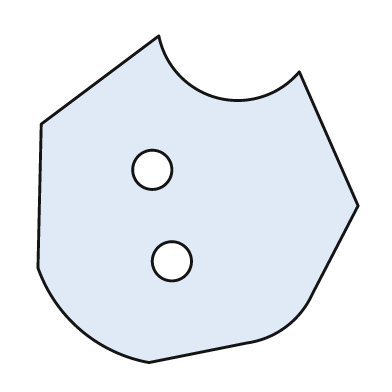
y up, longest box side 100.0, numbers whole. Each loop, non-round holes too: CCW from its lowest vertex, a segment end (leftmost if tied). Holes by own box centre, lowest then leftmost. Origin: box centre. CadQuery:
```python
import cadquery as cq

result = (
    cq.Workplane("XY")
    .moveTo(-15.0, -50.0)
    .lineTo(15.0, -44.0)
    .threePointArc((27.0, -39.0), (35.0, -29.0))
    .lineTo(49.0, -2.0)
    .lineTo(31.0, 39.0)
    .threePointArc((6.0, 31.0), (-12.0, 50.0))
    .lineTo(-48.0, 23.0)
    .lineTo(-49.0, -21.0)
    .threePointArc((-36.0, -40.0), (-15.0, -50.0))
    .close()
    .moveTo(-8.0, -19.0)
    .circle(6.0)
    .moveTo(-14.0, 9.0)
    .circle(6.0)
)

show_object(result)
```